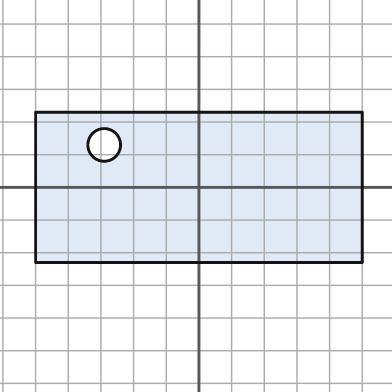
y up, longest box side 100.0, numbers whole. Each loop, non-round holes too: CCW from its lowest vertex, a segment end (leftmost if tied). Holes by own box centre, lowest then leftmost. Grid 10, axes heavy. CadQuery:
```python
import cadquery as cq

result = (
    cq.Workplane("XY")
    .moveTo(-50.0, -23.0)
    .lineTo(50.0, -23.0)
    .lineTo(50.0, 23.0)
    .lineTo(-50.0, 23.0)
    .close()
    .moveTo(-29.0, 13.0)
    .circle(5.0)
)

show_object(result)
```